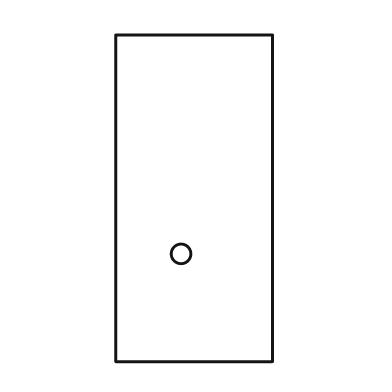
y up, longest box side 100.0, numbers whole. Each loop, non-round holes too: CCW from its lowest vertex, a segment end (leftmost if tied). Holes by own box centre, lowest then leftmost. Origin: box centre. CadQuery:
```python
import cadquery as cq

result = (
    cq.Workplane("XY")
    .moveTo(-24.0, -50.0)
    .lineTo(24.0, -50.0)
    .lineTo(24.0, 50.0)
    .lineTo(-24.0, 50.0)
    .close()
    .moveTo(-4.0, -17.0)
    .circle(3.0)
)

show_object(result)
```